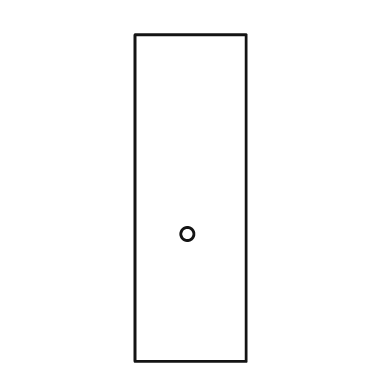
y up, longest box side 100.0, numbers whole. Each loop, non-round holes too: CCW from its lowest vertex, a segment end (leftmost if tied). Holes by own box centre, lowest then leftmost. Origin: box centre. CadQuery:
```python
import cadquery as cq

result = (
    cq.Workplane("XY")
    .moveTo(-17.0, -50.0)
    .lineTo(17.0, -50.0)
    .lineTo(17.0, 50.0)
    .lineTo(-17.0, 50.0)
    .close()
    .moveTo(-1.0, -11.0)
    .circle(2.0)
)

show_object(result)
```